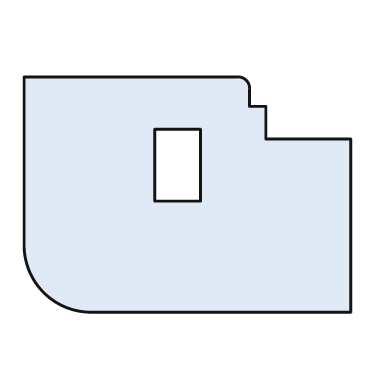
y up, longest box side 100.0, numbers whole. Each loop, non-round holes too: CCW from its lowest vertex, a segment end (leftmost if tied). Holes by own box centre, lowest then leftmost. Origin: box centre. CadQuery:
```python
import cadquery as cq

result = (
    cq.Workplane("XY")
    .moveTo(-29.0, -36.0)
    .lineTo(50.0, -36.0)
    .lineTo(50.0, 17.0)
    .lineTo(24.0, 17.0)
    .lineTo(24.0, 27.0)
    .lineTo(19.0, 27.0)
    .lineTo(19.0, 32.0)
    .threePointArc((18.0, 35.0), (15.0, 36.0))
    .lineTo(-50.0, 36.0)
    .lineTo(-50.0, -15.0)
    .threePointArc((-44.0, -30.0), (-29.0, -36.0))
    .close()
    .moveTo(-10.0, -2.0)
    .lineTo(4.0, -2.0)
    .lineTo(4.0, 20.0)
    .lineTo(-10.0, 20.0)
    .close()
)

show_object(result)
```